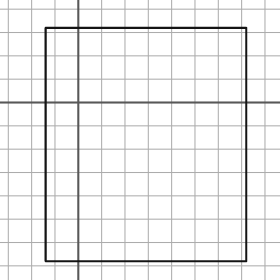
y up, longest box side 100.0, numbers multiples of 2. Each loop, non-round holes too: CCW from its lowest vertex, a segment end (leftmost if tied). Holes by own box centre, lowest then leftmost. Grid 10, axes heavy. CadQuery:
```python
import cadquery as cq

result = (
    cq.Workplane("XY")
    .moveTo(-14.0, -68.0)
    .lineTo(72.0, -68.0)
    .lineTo(72.0, 32.0)
    .lineTo(-14.0, 32.0)
    .close()
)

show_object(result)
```